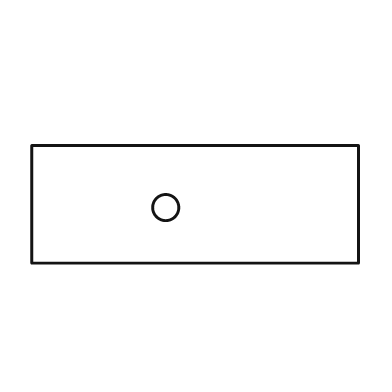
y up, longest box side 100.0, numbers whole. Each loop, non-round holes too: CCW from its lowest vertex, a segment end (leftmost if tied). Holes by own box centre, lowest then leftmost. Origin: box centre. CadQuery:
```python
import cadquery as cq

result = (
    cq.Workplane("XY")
    .moveTo(-50.0, -18.0)
    .lineTo(50.0, -18.0)
    .lineTo(50.0, 18.0)
    .lineTo(-50.0, 18.0)
    .close()
    .moveTo(-9.0, -1.0)
    .circle(4.0)
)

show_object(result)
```